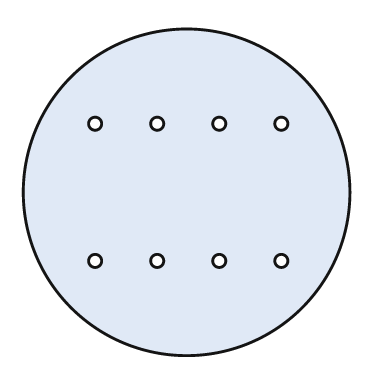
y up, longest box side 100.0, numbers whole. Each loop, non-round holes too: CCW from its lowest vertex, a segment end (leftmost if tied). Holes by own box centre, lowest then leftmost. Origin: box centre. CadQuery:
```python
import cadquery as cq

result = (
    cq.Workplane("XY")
    .moveTo(0.0, 0.0)
    .circle(50.0)
    .moveTo(-28.0, -21.0)
    .circle(2.0)
    .moveTo(-9.0, -21.0)
    .circle(2.0)
    .moveTo(10.0, -21.0)
    .circle(2.0)
    .moveTo(29.0, -21.0)
    .circle(2.0)
    .moveTo(-28.0, 21.0)
    .circle(2.0)
    .moveTo(-9.0, 21.0)
    .circle(2.0)
    .moveTo(10.0, 21.0)
    .circle(2.0)
    .moveTo(29.0, 21.0)
    .circle(2.0)
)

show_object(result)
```